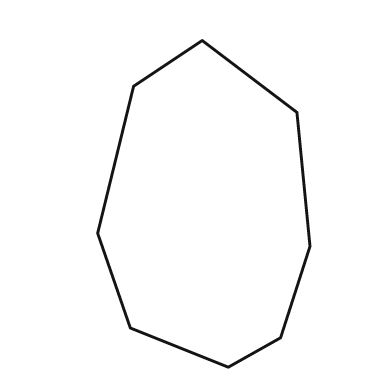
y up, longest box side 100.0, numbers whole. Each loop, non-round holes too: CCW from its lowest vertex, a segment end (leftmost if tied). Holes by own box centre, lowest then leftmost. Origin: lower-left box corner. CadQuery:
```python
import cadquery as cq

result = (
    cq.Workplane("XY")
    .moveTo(40.0, 0.0)
    .lineTo(56.0, 9.0)
    .lineTo(65.0, 37.0)
    .lineTo(61.0, 78.0)
    .lineTo(32.0, 100.0)
    .lineTo(11.0, 86.0)
    .lineTo(0.0, 41.0)
    .lineTo(10.0, 12.0)
    .close()
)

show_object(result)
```